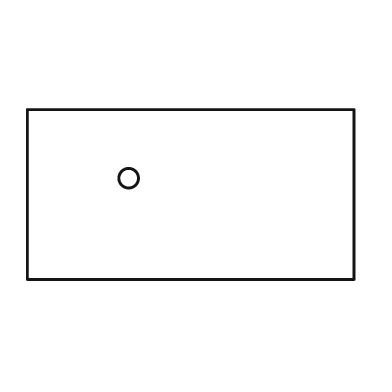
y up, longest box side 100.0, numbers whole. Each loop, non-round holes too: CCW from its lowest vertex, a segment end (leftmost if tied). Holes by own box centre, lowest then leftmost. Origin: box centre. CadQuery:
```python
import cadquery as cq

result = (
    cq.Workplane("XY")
    .moveTo(-50.0, -26.0)
    .lineTo(50.0, -26.0)
    .lineTo(50.0, 26.0)
    .lineTo(-50.0, 26.0)
    .close()
    .moveTo(-19.0, 5.0)
    .circle(3.0)
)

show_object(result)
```